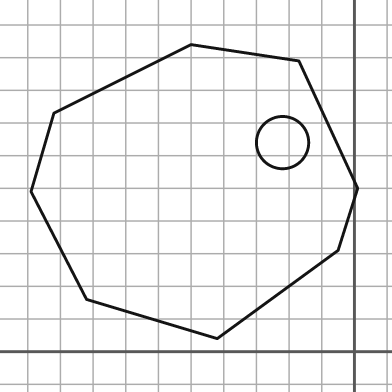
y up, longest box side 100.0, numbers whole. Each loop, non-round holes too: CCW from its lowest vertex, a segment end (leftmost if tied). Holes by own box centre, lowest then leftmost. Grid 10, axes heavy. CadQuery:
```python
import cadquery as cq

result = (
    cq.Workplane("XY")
    .moveTo(-42.0, 4.0)
    .lineTo(-5.0, 31.0)
    .lineTo(1.0, 50.0)
    .lineTo(-17.0, 89.0)
    .lineTo(-50.0, 94.0)
    .lineTo(-92.0, 73.0)
    .lineTo(-99.0, 49.0)
    .lineTo(-82.0, 16.0)
    .close()
    .moveTo(-22.0, 64.0)
    .circle(8.0)
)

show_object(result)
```